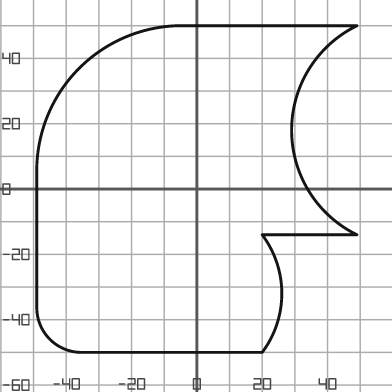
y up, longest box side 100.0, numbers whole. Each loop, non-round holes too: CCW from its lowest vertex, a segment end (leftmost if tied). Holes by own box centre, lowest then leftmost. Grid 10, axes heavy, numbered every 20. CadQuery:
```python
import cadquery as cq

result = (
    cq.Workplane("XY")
    .moveTo(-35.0, -50.0)
    .lineTo(20.0, -50.0)
    .threePointArc((26.0, -32.0), (20.0, -14.0))
    .lineTo(49.0, -14.0)
    .threePointArc((29.0, 18.0), (49.0, 50.0))
    .lineTo(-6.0, 50.0)
    .threePointArc((-36.0, 37.0), (-49.0, 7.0))
    .lineTo(-49.0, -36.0)
    .threePointArc((-45.0, -46.0), (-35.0, -50.0))
    .close()
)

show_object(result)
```